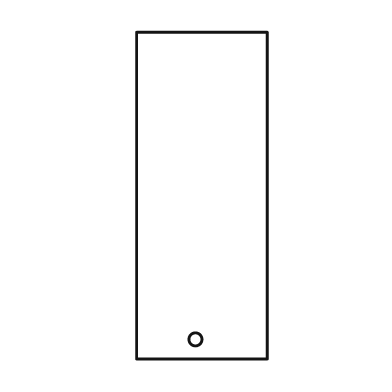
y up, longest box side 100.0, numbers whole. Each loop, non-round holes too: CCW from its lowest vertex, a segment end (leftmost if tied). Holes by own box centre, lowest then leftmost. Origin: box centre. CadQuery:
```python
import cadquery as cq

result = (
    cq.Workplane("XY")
    .moveTo(-20.0, -50.0)
    .lineTo(20.0, -50.0)
    .lineTo(20.0, 50.0)
    .lineTo(-20.0, 50.0)
    .close()
    .moveTo(-2.0, -44.0)
    .circle(2.0)
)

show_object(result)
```